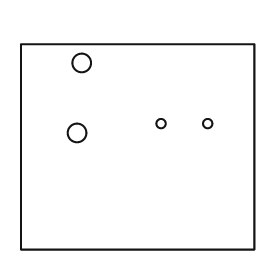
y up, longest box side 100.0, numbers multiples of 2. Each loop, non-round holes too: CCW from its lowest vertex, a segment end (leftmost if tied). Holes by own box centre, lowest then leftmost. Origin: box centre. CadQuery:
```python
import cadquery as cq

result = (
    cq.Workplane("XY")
    .moveTo(-50.0, -44.0)
    .lineTo(50.0, -44.0)
    .lineTo(50.0, 44.0)
    .lineTo(-50.0, 44.0)
    .close()
    .moveTo(-26.0, 6.0)
    .circle(4.0)
    .moveTo(10.0, 10.0)
    .circle(2.0)
    .moveTo(30.0, 10.0)
    .circle(2.0)
    .moveTo(-24.0, 36.0)
    .circle(4.0)
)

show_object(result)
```